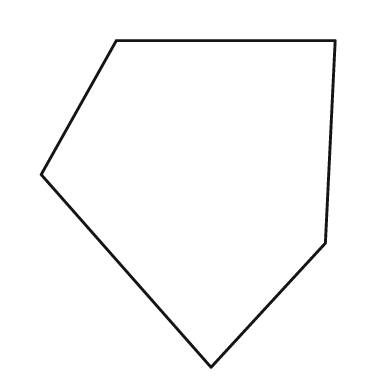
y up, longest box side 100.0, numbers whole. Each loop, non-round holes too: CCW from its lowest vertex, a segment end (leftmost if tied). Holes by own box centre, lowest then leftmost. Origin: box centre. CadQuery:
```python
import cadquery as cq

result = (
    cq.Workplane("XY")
    .moveTo(7.0, -50.0)
    .lineTo(42.0, -12.0)
    .lineTo(45.0, 50.0)
    .lineTo(-22.0, 50.0)
    .lineTo(-45.0, 9.0)
    .close()
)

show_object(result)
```